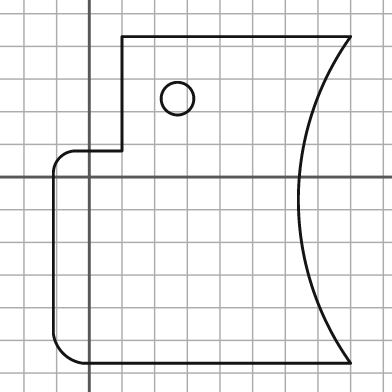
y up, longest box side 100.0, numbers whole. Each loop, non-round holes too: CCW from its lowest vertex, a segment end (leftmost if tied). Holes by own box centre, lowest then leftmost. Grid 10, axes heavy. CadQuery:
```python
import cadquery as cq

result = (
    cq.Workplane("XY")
    .moveTo(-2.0, -57.0)
    .lineTo(80.0, -57.0)
    .threePointArc((64.0, -7.0), (80.0, 43.0))
    .lineTo(10.0, 43.0)
    .lineTo(10.0, 8.0)
    .lineTo(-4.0, 8.0)
    .threePointArc((-9.0, 6.0), (-11.0, 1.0))
    .lineTo(-11.0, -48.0)
    .threePointArc((-8.0, -54.0), (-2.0, -57.0))
    .close()
    .moveTo(27.0, 24.0)
    .circle(5.0)
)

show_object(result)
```